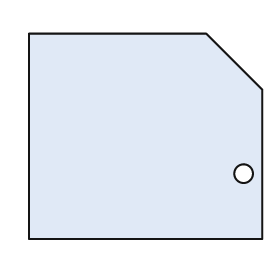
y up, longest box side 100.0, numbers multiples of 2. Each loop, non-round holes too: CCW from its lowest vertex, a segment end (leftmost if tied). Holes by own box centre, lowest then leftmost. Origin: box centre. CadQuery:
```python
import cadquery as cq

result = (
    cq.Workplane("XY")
    .moveTo(-50.0, -44.0)
    .lineTo(50.0, -44.0)
    .lineTo(50.0, 20.0)
    .lineTo(26.0, 44.0)
    .lineTo(-50.0, 44.0)
    .close()
    .moveTo(42.0, -16.0)
    .circle(4.0)
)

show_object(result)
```